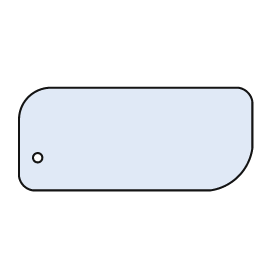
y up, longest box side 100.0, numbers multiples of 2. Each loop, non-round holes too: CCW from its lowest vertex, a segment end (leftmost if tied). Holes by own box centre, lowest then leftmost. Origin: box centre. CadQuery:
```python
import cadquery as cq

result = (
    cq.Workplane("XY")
    .moveTo(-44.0, -22.0)
    .lineTo(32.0, -22.0)
    .threePointArc((44.0, -16.0), (50.0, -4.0))
    .lineTo(50.0, 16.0)
    .threePointArc((48.0, 20.0), (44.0, 22.0))
    .lineTo(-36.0, 22.0)
    .threePointArc((-46.0, 18.0), (-50.0, 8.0))
    .lineTo(-50.0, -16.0)
    .threePointArc((-48.0, -20.0), (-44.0, -22.0))
    .close()
    .moveTo(-42.0, -8.0)
    .circle(2.0)
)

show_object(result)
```